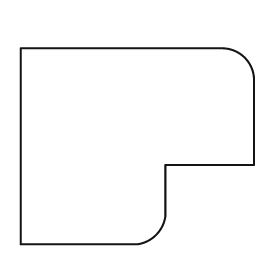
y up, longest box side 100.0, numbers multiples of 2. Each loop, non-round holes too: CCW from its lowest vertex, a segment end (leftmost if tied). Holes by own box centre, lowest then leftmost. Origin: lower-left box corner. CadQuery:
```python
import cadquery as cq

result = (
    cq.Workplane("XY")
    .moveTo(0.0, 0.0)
    .lineTo(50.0, 0.0)
    .threePointArc((58.0, 4.0), (62.0, 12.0))
    .lineTo(62.0, 34.0)
    .lineTo(100.0, 34.0)
    .lineTo(100.0, 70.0)
    .threePointArc((96.0, 80.0), (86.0, 84.0))
    .lineTo(0.0, 84.0)
    .close()
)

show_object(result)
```